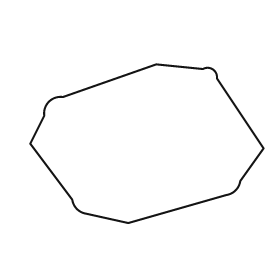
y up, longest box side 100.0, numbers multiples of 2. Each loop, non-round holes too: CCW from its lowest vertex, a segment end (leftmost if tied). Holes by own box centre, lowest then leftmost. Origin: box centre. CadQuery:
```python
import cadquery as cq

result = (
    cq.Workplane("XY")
    .moveTo(-8.0, -34.0)
    .lineTo(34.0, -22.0)
    .threePointArc((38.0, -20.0), (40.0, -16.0))
    .lineTo(50.0, -2.0)
    .lineTo(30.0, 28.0)
    .threePointArc((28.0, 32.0), (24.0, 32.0))
    .lineTo(4.0, 34.0)
    .lineTo(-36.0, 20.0)
    .threePointArc((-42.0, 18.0), (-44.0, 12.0))
    .lineTo(-50.0, 0.0)
    .lineTo(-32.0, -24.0)
    .threePointArc((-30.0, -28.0), (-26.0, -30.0))
    .close()
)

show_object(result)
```